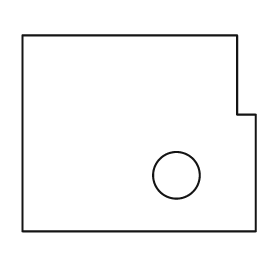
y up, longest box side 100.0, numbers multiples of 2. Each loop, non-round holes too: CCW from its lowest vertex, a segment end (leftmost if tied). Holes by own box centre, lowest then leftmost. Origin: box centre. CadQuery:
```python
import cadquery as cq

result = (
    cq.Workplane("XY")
    .moveTo(-50.0, -42.0)
    .lineTo(50.0, -42.0)
    .lineTo(50.0, 8.0)
    .lineTo(42.0, 8.0)
    .lineTo(42.0, 42.0)
    .lineTo(-50.0, 42.0)
    .close()
    .moveTo(16.0, -18.0)
    .circle(10.0)
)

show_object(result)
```